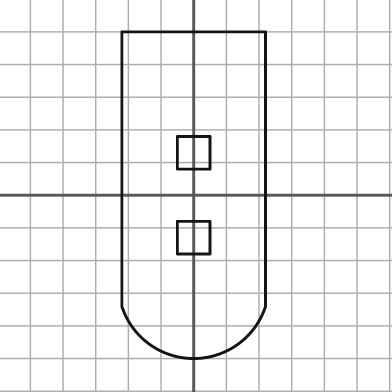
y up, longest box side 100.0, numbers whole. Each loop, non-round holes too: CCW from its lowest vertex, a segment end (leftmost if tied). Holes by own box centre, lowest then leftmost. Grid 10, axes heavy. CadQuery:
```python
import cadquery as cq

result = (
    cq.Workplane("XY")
    .moveTo(-22.0, -34.0)
    .threePointArc((0.0, -50.0), (22.0, -34.0))
    .lineTo(22.0, 50.0)
    .lineTo(-22.0, 50.0)
    .close()
    .moveTo(-5.0, -18.0)
    .lineTo(5.0, -18.0)
    .lineTo(5.0, -8.0)
    .lineTo(-5.0, -8.0)
    .close()
    .moveTo(-5.0, 8.0)
    .lineTo(5.0, 8.0)
    .lineTo(5.0, 18.0)
    .lineTo(-5.0, 18.0)
    .close()
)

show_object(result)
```